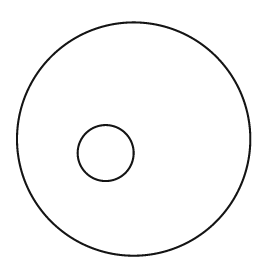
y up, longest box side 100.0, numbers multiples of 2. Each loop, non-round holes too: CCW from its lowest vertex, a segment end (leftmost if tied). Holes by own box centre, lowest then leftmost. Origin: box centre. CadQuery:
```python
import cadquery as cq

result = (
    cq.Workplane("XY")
    .moveTo(0.0, 0.0)
    .circle(50.0)
    .moveTo(-12.0, -6.0)
    .circle(12.0)
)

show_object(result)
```